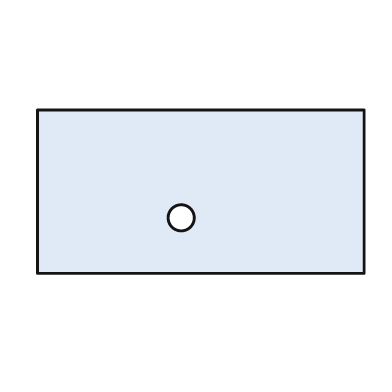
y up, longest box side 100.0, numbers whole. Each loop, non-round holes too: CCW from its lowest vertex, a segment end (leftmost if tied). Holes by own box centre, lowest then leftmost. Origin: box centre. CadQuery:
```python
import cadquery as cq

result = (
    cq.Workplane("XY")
    .moveTo(-50.0, -25.0)
    .lineTo(50.0, -25.0)
    .lineTo(50.0, 25.0)
    .lineTo(-50.0, 25.0)
    .close()
    .moveTo(-6.0, -8.0)
    .circle(4.0)
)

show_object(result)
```